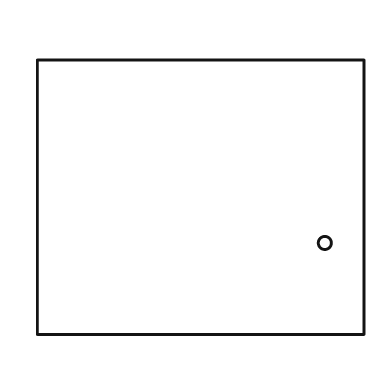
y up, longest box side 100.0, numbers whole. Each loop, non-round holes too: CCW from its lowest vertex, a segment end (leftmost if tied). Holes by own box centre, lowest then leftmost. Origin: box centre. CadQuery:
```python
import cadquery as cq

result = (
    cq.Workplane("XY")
    .moveTo(-50.0, -42.0)
    .lineTo(50.0, -42.0)
    .lineTo(50.0, 42.0)
    .lineTo(-50.0, 42.0)
    .close()
    .moveTo(38.0, -14.0)
    .circle(2.0)
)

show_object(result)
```